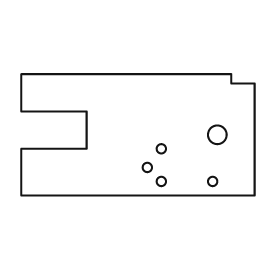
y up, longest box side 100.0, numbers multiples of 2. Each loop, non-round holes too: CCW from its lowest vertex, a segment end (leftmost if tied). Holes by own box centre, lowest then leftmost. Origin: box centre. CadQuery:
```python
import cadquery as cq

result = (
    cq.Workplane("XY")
    .moveTo(-50.0, -26.0)
    .lineTo(50.0, -26.0)
    .lineTo(50.0, 22.0)
    .lineTo(40.0, 22.0)
    .lineTo(40.0, 26.0)
    .lineTo(-50.0, 26.0)
    .lineTo(-50.0, 10.0)
    .lineTo(-22.0, 10.0)
    .lineTo(-22.0, -6.0)
    .lineTo(-50.0, -6.0)
    .close()
    .moveTo(10.0, -20.0)
    .circle(2.0)
    .moveTo(32.0, -20.0)
    .circle(2.0)
    .moveTo(4.0, -14.0)
    .circle(2.0)
    .moveTo(10.0, -6.0)
    .circle(2.0)
    .moveTo(34.0, 0.0)
    .circle(4.0)
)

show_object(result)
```